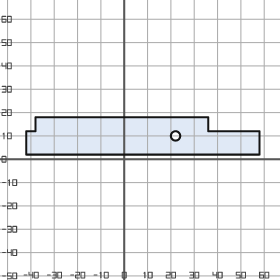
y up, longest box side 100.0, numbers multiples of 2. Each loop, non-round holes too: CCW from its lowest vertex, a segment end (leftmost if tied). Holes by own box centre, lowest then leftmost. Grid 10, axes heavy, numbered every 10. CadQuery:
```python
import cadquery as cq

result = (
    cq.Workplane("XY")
    .moveTo(-42.0, 2.0)
    .lineTo(58.0, 2.0)
    .lineTo(58.0, 12.0)
    .lineTo(36.0, 12.0)
    .lineTo(36.0, 18.0)
    .lineTo(-38.0, 18.0)
    .lineTo(-38.0, 12.0)
    .lineTo(-42.0, 12.0)
    .close()
    .moveTo(22.0, 10.0)
    .circle(2.0)
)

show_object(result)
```